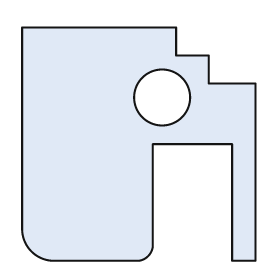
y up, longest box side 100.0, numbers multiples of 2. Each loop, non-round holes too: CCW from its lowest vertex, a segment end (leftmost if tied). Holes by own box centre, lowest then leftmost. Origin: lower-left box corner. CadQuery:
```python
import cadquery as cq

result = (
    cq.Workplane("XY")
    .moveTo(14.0, 0.0)
    .lineTo(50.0, 0.0)
    .threePointArc((54.0, 2.0), (56.0, 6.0))
    .lineTo(56.0, 50.0)
    .lineTo(90.0, 50.0)
    .lineTo(90.0, 0.0)
    .lineTo(100.0, 0.0)
    .lineTo(100.0, 76.0)
    .lineTo(80.0, 76.0)
    .lineTo(80.0, 88.0)
    .lineTo(66.0, 88.0)
    .lineTo(66.0, 100.0)
    .lineTo(0.0, 100.0)
    .lineTo(0.0, 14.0)
    .threePointArc((4.0, 4.0), (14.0, 0.0))
    .close()
    .moveTo(60.0, 70.0)
    .circle(12.0)
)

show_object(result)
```